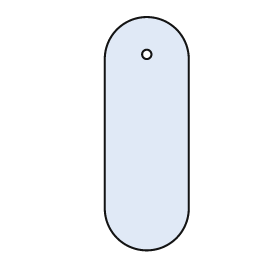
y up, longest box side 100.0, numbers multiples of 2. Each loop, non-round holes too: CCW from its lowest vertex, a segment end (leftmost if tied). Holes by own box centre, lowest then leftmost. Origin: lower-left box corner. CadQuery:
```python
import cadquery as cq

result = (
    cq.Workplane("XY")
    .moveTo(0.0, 18.0)
    .threePointArc((18.0, 0.0), (36.0, 18.0))
    .lineTo(36.0, 82.0)
    .threePointArc((18.0, 100.0), (0.0, 82.0))
    .close()
    .moveTo(18.0, 84.0)
    .circle(2.0)
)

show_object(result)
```